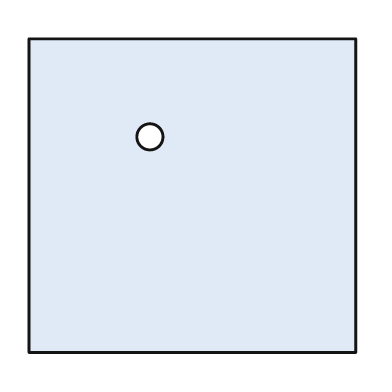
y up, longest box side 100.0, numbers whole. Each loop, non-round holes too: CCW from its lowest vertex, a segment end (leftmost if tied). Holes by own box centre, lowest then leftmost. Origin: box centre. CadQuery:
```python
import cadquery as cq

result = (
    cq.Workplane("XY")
    .moveTo(-50.0, -48.0)
    .lineTo(50.0, -48.0)
    .lineTo(50.0, 48.0)
    .lineTo(-50.0, 48.0)
    .close()
    .moveTo(-13.0, 18.0)
    .circle(4.0)
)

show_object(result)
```